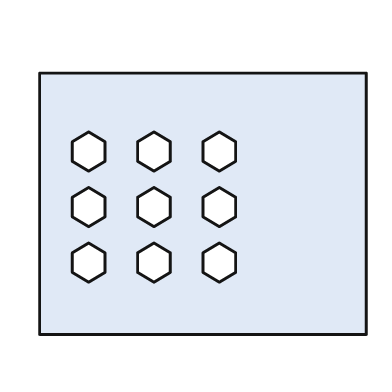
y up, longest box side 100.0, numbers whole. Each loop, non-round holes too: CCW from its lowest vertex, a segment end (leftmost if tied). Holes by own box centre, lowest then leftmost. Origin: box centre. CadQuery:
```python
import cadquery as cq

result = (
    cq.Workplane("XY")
    .moveTo(-50.0, -40.0)
    .lineTo(50.0, -40.0)
    .lineTo(50.0, 40.0)
    .lineTo(-50.0, 40.0)
    .close()
    .moveTo(-35.0, -24.0)
    .lineTo(-30.0, -21.0)
    .lineTo(-30.0, -15.0)
    .lineTo(-35.0, -12.0)
    .lineTo(-40.0, -15.0)
    .lineTo(-40.0, -21.0)
    .close()
    .moveTo(-15.0, -24.0)
    .lineTo(-10.0, -21.0)
    .lineTo(-10.0, -15.0)
    .lineTo(-15.0, -12.0)
    .lineTo(-20.0, -15.0)
    .lineTo(-20.0, -21.0)
    .close()
    .moveTo(5.0, -24.0)
    .lineTo(10.0, -21.0)
    .lineTo(10.0, -15.0)
    .lineTo(5.0, -12.0)
    .lineTo(0.0, -15.0)
    .lineTo(0.0, -21.0)
    .close()
    .moveTo(-35.0, -7.0)
    .lineTo(-30.0, -4.0)
    .lineTo(-30.0, 2.0)
    .lineTo(-35.0, 5.0)
    .lineTo(-40.0, 2.0)
    .lineTo(-40.0, -4.0)
    .close()
    .moveTo(-15.0, -7.0)
    .lineTo(-10.0, -4.0)
    .lineTo(-10.0, 2.0)
    .lineTo(-15.0, 5.0)
    .lineTo(-20.0, 2.0)
    .lineTo(-20.0, -4.0)
    .close()
    .moveTo(5.0, -7.0)
    .lineTo(10.0, -4.0)
    .lineTo(10.0, 2.0)
    .lineTo(5.0, 5.0)
    .lineTo(0.0, 2.0)
    .lineTo(0.0, -4.0)
    .close()
    .moveTo(-35.0, 10.0)
    .lineTo(-30.0, 13.0)
    .lineTo(-30.0, 19.0)
    .lineTo(-35.0, 22.0)
    .lineTo(-40.0, 19.0)
    .lineTo(-40.0, 13.0)
    .close()
    .moveTo(-15.0, 10.0)
    .lineTo(-10.0, 13.0)
    .lineTo(-10.0, 19.0)
    .lineTo(-15.0, 22.0)
    .lineTo(-20.0, 19.0)
    .lineTo(-20.0, 13.0)
    .close()
    .moveTo(5.0, 10.0)
    .lineTo(10.0, 13.0)
    .lineTo(10.0, 19.0)
    .lineTo(5.0, 22.0)
    .lineTo(0.0, 19.0)
    .lineTo(0.0, 13.0)
    .close()
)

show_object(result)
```